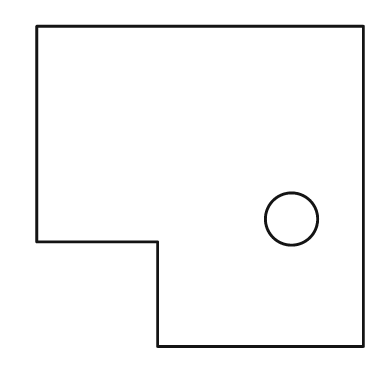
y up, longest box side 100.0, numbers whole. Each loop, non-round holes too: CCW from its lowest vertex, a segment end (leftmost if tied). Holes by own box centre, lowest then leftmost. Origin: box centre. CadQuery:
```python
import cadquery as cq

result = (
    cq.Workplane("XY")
    .moveTo(-13.0, -49.0)
    .lineTo(50.0, -49.0)
    .lineTo(50.0, 49.0)
    .lineTo(-50.0, 49.0)
    .lineTo(-50.0, -17.0)
    .lineTo(-13.0, -17.0)
    .close()
    .moveTo(28.0, -10.0)
    .circle(8.0)
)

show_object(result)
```